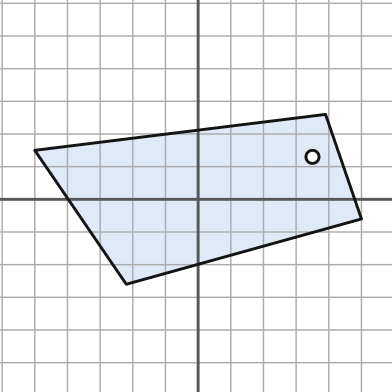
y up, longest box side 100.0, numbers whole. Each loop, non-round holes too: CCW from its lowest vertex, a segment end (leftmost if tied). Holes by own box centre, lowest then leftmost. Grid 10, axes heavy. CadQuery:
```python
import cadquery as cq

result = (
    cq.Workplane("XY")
    .moveTo(-22.0, -26.0)
    .lineTo(50.0, -6.0)
    .lineTo(39.0, 26.0)
    .lineTo(-50.0, 15.0)
    .close()
    .moveTo(35.0, 13.0)
    .circle(2.0)
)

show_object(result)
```